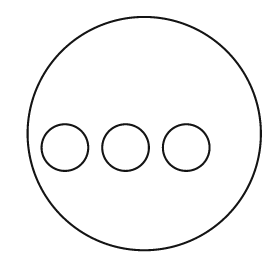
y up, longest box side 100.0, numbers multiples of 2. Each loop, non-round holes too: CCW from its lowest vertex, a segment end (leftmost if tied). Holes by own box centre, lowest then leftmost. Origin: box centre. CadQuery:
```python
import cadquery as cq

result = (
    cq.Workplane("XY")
    .moveTo(0.0, 0.0)
    .circle(50.0)
    .moveTo(-34.0, -6.0)
    .circle(10.0)
    .moveTo(-8.0, -6.0)
    .circle(10.0)
    .moveTo(18.0, -6.0)
    .circle(10.0)
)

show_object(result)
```